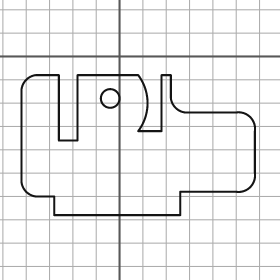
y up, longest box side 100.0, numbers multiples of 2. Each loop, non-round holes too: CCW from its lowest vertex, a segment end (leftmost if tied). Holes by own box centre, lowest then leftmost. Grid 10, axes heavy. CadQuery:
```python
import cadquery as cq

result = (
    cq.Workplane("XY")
    .moveTo(-28.0, -68.0)
    .lineTo(26.0, -68.0)
    .lineTo(26.0, -58.0)
    .lineTo(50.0, -58.0)
    .threePointArc((56.0, -56.0), (58.0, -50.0))
    .lineTo(58.0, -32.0)
    .threePointArc((56.0, -26.0), (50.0, -24.0))
    .lineTo(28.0, -24.0)
    .threePointArc((24.0, -22.0), (22.0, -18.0))
    .lineTo(22.0, -8.0)
    .lineTo(18.0, -8.0)
    .lineTo(18.0, -32.0)
    .lineTo(8.0, -32.0)
    .threePointArc((12.0, -20.0), (8.0, -8.0))
    .lineTo(-18.0, -8.0)
    .lineTo(-18.0, -36.0)
    .lineTo(-26.0, -36.0)
    .lineTo(-26.0, -8.0)
    .lineTo(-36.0, -8.0)
    .threePointArc((-40.0, -10.0), (-42.0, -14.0))
    .lineTo(-42.0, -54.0)
    .threePointArc((-40.0, -58.0), (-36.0, -60.0))
    .lineTo(-28.0, -60.0)
    .close()
    .moveTo(-4.0, -18.0)
    .circle(4.0)
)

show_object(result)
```